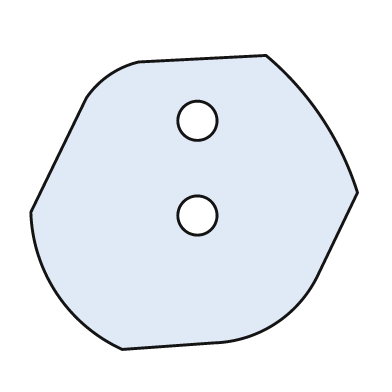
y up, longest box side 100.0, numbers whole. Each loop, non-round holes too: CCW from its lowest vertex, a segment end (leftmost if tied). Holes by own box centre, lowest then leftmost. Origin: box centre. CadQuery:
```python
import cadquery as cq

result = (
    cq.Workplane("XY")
    .moveTo(-22.0, -45.0)
    .lineTo(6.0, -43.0)
    .threePointArc((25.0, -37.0), (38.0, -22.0))
    .lineTo(50.0, 3.0)
    .threePointArc((39.0, 26.0), (22.0, 45.0))
    .lineTo(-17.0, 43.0)
    .threePointArc((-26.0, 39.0), (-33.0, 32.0))
    .lineTo(-50.0, -3.0)
    .threePointArc((-42.0, -28.0), (-22.0, -45.0))
    .close()
    .moveTo(1.0, -4.0)
    .circle(6.0)
    .moveTo(1.0, 25.0)
    .circle(6.0)
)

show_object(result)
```